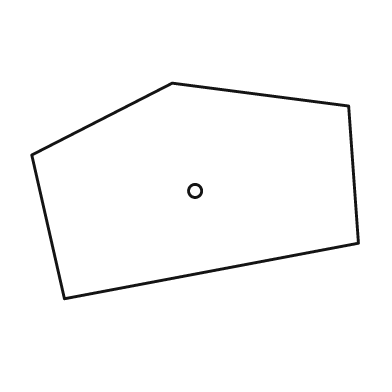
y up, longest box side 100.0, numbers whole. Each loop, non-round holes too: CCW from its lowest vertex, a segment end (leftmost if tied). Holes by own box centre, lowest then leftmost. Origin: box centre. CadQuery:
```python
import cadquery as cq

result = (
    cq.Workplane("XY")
    .moveTo(-40.0, -33.0)
    .lineTo(50.0, -16.0)
    .lineTo(47.0, 26.0)
    .lineTo(-7.0, 33.0)
    .lineTo(-50.0, 11.0)
    .close()
    .moveTo(0.0, 0.0)
    .circle(2.0)
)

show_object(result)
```